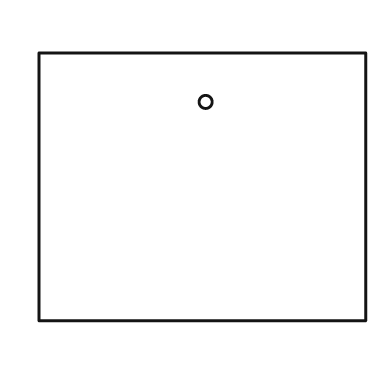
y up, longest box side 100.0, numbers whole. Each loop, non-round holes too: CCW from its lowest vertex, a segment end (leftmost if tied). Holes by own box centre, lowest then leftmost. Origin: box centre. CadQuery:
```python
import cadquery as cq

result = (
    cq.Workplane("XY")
    .moveTo(-50.0, -41.0)
    .lineTo(50.0, -41.0)
    .lineTo(50.0, 41.0)
    .lineTo(-50.0, 41.0)
    .close()
    .moveTo(1.0, 26.0)
    .circle(2.0)
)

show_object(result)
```